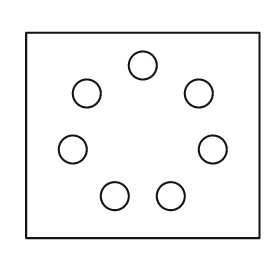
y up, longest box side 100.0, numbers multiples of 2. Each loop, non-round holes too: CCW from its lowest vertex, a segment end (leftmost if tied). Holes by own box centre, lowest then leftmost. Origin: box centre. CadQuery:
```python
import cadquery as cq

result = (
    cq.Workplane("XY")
    .moveTo(-50.0, -44.0)
    .lineTo(50.0, -44.0)
    .lineTo(50.0, 44.0)
    .lineTo(-50.0, 44.0)
    .close()
    .moveTo(-12.0, -26.0)
    .circle(6.0)
    .moveTo(12.0, -26.0)
    .circle(6.0)
    .moveTo(-30.0, -6.0)
    .circle(6.0)
    .moveTo(30.0, -6.0)
    .circle(6.0)
    .moveTo(-24.0, 18.0)
    .circle(6.0)
    .moveTo(24.0, 18.0)
    .circle(6.0)
    .moveTo(0.0, 30.0)
    .circle(6.0)
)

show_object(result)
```